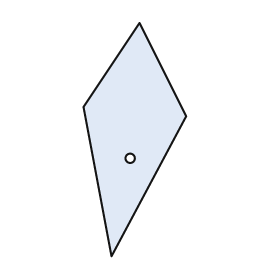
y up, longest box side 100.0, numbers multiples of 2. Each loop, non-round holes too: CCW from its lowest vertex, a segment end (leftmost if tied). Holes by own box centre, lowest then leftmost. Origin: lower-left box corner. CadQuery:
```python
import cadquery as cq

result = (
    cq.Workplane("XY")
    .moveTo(12.0, 0.0)
    .lineTo(44.0, 60.0)
    .lineTo(24.0, 100.0)
    .lineTo(0.0, 64.0)
    .close()
    .moveTo(20.0, 42.0)
    .circle(2.0)
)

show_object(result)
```